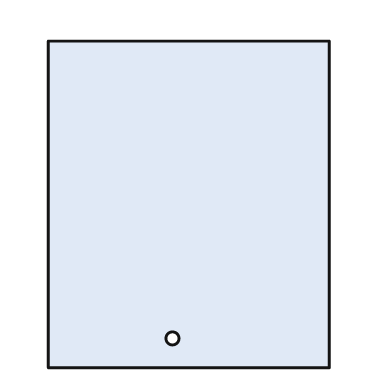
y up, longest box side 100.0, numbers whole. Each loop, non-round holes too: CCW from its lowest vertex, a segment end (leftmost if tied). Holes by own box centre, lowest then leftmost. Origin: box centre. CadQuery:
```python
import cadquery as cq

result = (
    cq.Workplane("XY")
    .moveTo(-43.0, -50.0)
    .lineTo(43.0, -50.0)
    .lineTo(43.0, 50.0)
    .lineTo(-43.0, 50.0)
    .close()
    .moveTo(-5.0, -41.0)
    .circle(2.0)
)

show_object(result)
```